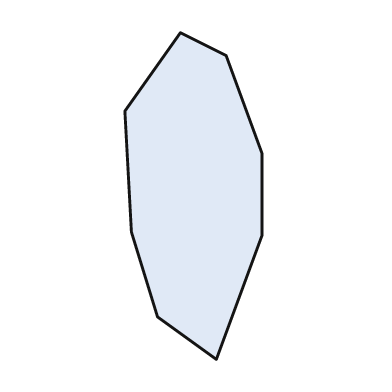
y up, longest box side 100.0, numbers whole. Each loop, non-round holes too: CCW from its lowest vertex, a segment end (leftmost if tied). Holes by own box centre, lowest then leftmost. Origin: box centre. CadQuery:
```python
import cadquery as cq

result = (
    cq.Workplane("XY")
    .moveTo(7.0, -50.0)
    .lineTo(21.0, -12.0)
    .lineTo(21.0, 13.0)
    .lineTo(10.0, 43.0)
    .lineTo(-4.0, 50.0)
    .lineTo(-21.0, 26.0)
    .lineTo(-19.0, -11.0)
    .lineTo(-11.0, -37.0)
    .close()
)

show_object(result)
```